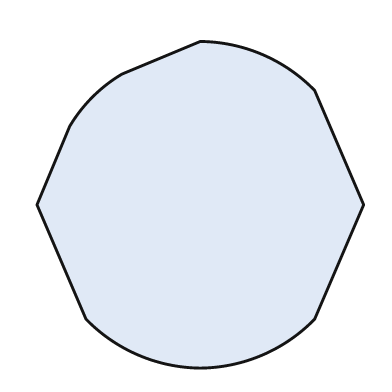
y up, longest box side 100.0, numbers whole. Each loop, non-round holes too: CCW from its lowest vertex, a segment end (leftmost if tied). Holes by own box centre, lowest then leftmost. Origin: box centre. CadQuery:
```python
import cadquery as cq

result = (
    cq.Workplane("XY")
    .moveTo(0.0, -50.0)
    .threePointArc((19.0, -46.0), (35.0, -35.0))
    .lineTo(50.0, 0.0)
    .lineTo(35.0, 35.0)
    .threePointArc((19.0, 46.0), (0.0, 50.0))
    .lineTo(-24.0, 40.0)
    .threePointArc((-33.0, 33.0), (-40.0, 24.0))
    .lineTo(-50.0, 0.0)
    .lineTo(-35.0, -35.0)
    .threePointArc((-19.0, -46.0), (0.0, -50.0))
    .close()
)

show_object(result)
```